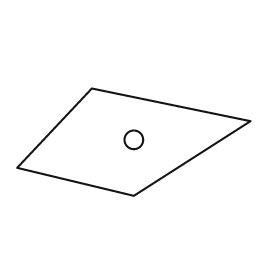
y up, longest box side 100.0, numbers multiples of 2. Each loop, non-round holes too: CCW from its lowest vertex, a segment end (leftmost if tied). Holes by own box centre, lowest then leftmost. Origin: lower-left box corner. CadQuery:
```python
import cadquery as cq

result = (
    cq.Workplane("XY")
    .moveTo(50.0, 0.0)
    .lineTo(100.0, 32.0)
    .lineTo(32.0, 46.0)
    .lineTo(0.0, 12.0)
    .close()
    .moveTo(50.0, 24.0)
    .circle(4.0)
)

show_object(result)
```